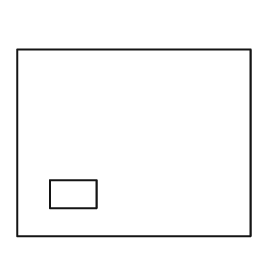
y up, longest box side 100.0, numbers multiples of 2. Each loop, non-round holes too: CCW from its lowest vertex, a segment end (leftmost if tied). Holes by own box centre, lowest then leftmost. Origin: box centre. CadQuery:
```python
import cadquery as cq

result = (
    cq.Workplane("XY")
    .moveTo(-50.0, -40.0)
    .lineTo(50.0, -40.0)
    .lineTo(50.0, 40.0)
    .lineTo(-50.0, 40.0)
    .close()
    .moveTo(-36.0, -28.0)
    .lineTo(-16.0, -28.0)
    .lineTo(-16.0, -16.0)
    .lineTo(-36.0, -16.0)
    .close()
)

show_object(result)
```